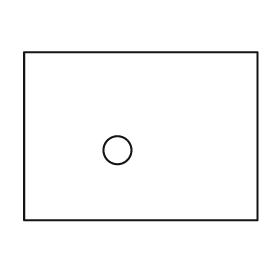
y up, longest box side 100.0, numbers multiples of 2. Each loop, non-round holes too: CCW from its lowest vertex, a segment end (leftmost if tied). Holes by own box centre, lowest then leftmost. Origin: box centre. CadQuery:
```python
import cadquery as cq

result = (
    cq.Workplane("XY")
    .moveTo(-50.0, -36.0)
    .lineTo(50.0, -36.0)
    .lineTo(50.0, 36.0)
    .lineTo(-50.0, 36.0)
    .close()
    .moveTo(-10.0, -6.0)
    .circle(6.0)
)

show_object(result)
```